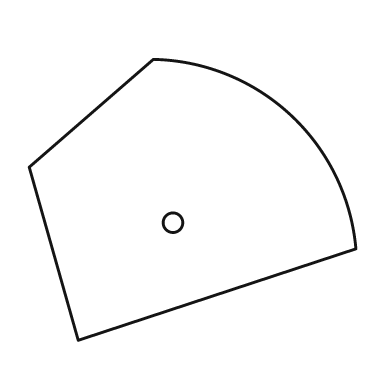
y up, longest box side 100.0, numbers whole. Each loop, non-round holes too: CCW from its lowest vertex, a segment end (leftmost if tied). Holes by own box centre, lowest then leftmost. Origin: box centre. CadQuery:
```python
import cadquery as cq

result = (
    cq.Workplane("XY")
    .moveTo(-35.0, -43.0)
    .lineTo(50.0, -15.0)
    .threePointArc((30.0, 26.0), (-12.0, 43.0))
    .lineTo(-50.0, 10.0)
    .close()
    .moveTo(-6.0, -7.0)
    .circle(3.0)
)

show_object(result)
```